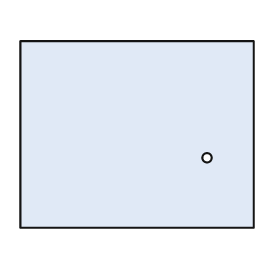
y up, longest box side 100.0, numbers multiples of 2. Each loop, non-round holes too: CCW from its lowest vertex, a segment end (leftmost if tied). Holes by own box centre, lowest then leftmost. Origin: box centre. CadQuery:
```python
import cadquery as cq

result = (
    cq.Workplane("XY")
    .moveTo(-50.0, -40.0)
    .lineTo(50.0, -40.0)
    .lineTo(50.0, 40.0)
    .lineTo(-50.0, 40.0)
    .close()
    .moveTo(30.0, -10.0)
    .circle(2.0)
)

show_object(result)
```